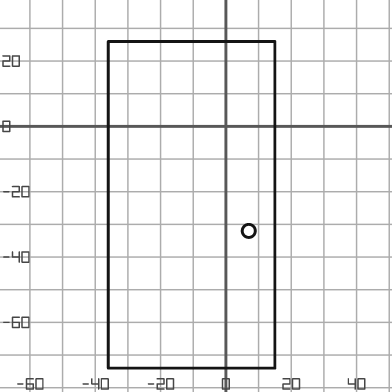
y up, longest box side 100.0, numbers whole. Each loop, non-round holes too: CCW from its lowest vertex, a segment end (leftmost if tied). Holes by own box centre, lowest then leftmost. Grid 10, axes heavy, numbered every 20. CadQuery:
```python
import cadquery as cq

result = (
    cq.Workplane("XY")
    .moveTo(-36.0, -74.0)
    .lineTo(15.0, -74.0)
    .lineTo(15.0, 26.0)
    .lineTo(-36.0, 26.0)
    .close()
    .moveTo(7.0, -32.0)
    .circle(2.0)
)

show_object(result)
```